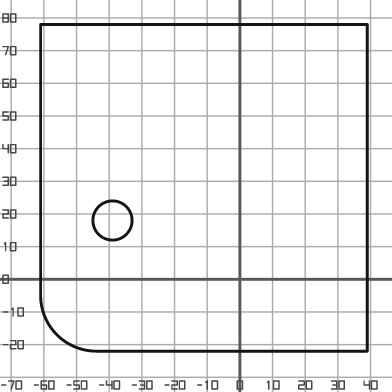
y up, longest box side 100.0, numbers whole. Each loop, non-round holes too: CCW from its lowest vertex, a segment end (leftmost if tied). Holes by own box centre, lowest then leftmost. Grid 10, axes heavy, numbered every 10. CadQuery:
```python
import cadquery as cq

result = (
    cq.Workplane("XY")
    .moveTo(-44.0, -22.0)
    .lineTo(39.0, -22.0)
    .lineTo(39.0, 78.0)
    .lineTo(-61.0, 78.0)
    .lineTo(-61.0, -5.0)
    .threePointArc((-56.0, -17.0), (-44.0, -22.0))
    .close()
    .moveTo(-39.0, 18.0)
    .circle(6.0)
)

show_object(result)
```